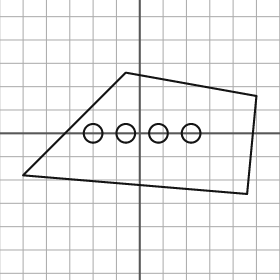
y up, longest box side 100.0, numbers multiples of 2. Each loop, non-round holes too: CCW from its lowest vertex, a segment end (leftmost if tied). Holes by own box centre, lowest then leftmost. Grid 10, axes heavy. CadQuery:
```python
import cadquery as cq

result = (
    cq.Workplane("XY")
    .moveTo(46.0, -26.0)
    .lineTo(50.0, 16.0)
    .lineTo(-6.0, 26.0)
    .lineTo(-50.0, -18.0)
    .close()
    .moveTo(-20.0, 0.0)
    .circle(4.0)
    .moveTo(-6.0, 0.0)
    .circle(4.0)
    .moveTo(8.0, 0.0)
    .circle(4.0)
    .moveTo(22.0, 0.0)
    .circle(4.0)
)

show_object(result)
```